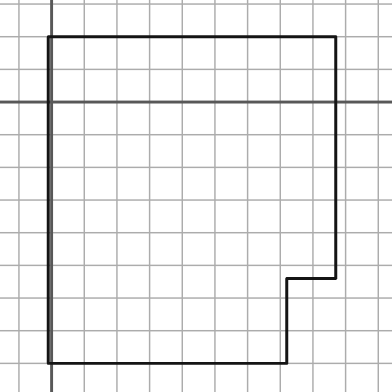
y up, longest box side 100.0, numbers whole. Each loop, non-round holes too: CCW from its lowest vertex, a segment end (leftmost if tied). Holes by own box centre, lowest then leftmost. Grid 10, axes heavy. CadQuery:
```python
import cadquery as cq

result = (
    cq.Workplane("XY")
    .moveTo(-1.0, -80.0)
    .lineTo(72.0, -80.0)
    .lineTo(72.0, -54.0)
    .lineTo(87.0, -54.0)
    .lineTo(87.0, 20.0)
    .lineTo(-1.0, 20.0)
    .close()
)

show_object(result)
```